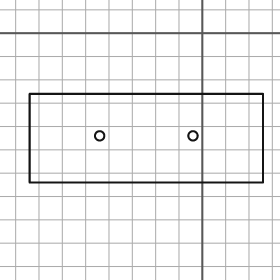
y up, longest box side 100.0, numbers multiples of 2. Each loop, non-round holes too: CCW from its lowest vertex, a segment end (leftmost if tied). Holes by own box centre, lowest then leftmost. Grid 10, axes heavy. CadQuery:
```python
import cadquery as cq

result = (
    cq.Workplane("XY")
    .moveTo(-74.0, -64.0)
    .lineTo(26.0, -64.0)
    .lineTo(26.0, -26.0)
    .lineTo(-74.0, -26.0)
    .close()
    .moveTo(-44.0, -44.0)
    .circle(2.0)
    .moveTo(-4.0, -44.0)
    .circle(2.0)
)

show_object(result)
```